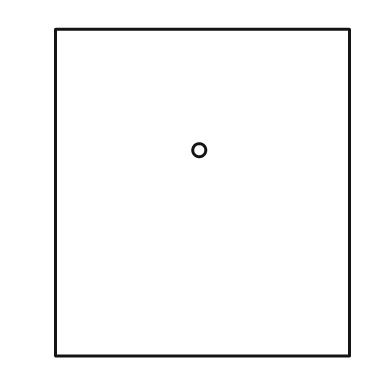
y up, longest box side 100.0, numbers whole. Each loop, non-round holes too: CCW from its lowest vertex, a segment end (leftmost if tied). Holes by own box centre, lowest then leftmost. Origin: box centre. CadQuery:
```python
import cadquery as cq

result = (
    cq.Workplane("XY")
    .moveTo(-45.0, -50.0)
    .lineTo(45.0, -50.0)
    .lineTo(45.0, 50.0)
    .lineTo(-45.0, 50.0)
    .close()
    .moveTo(-1.0, 13.0)
    .circle(2.0)
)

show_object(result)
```